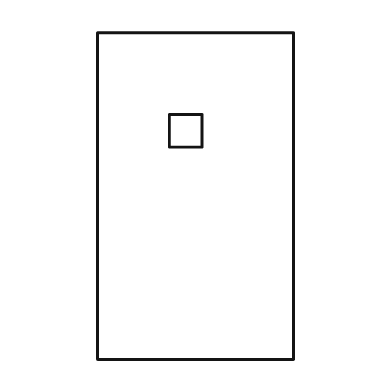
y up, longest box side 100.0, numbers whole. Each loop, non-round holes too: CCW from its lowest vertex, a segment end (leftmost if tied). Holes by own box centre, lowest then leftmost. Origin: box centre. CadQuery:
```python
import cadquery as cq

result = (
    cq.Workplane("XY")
    .moveTo(-30.0, -50.0)
    .lineTo(30.0, -50.0)
    .lineTo(30.0, 50.0)
    .lineTo(-30.0, 50.0)
    .close()
    .moveTo(-8.0, 15.0)
    .lineTo(2.0, 15.0)
    .lineTo(2.0, 25.0)
    .lineTo(-8.0, 25.0)
    .close()
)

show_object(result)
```